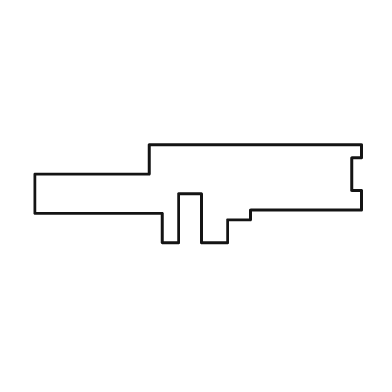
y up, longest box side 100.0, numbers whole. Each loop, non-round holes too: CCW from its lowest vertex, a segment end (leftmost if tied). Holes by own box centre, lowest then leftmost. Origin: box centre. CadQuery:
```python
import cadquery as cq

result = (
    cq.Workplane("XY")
    .moveTo(-11.0, -15.0)
    .lineTo(-6.0, -15.0)
    .lineTo(-6.0, 0.0)
    .lineTo(1.0, 0.0)
    .lineTo(1.0, -15.0)
    .lineTo(9.0, -15.0)
    .lineTo(9.0, -8.0)
    .lineTo(16.0, -8.0)
    .lineTo(16.0, -5.0)
    .lineTo(50.0, -5.0)
    .lineTo(50.0, 1.0)
    .lineTo(47.0, 1.0)
    .lineTo(47.0, 11.0)
    .lineTo(50.0, 11.0)
    .lineTo(50.0, 15.0)
    .lineTo(-15.0, 15.0)
    .lineTo(-15.0, 6.0)
    .lineTo(-50.0, 6.0)
    .lineTo(-50.0, -6.0)
    .lineTo(-11.0, -6.0)
    .close()
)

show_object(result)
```